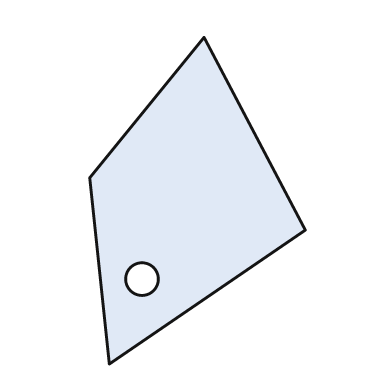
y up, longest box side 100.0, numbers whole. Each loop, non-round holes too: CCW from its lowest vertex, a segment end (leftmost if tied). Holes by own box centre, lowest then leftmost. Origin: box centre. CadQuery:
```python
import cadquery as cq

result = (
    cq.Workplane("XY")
    .moveTo(-27.0, -50.0)
    .lineTo(33.0, -9.0)
    .lineTo(2.0, 50.0)
    .lineTo(-33.0, 7.0)
    .close()
    .moveTo(-17.0, -24.0)
    .circle(5.0)
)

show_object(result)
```